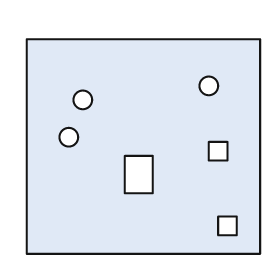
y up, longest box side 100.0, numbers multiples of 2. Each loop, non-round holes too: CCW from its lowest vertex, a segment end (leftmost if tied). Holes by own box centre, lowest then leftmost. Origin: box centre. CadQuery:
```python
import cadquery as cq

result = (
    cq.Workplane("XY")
    .moveTo(-50.0, -46.0)
    .lineTo(50.0, -46.0)
    .lineTo(50.0, 46.0)
    .lineTo(-50.0, 46.0)
    .close()
    .moveTo(32.0, -38.0)
    .lineTo(40.0, -38.0)
    .lineTo(40.0, -30.0)
    .lineTo(32.0, -30.0)
    .close()
    .moveTo(-8.0, -20.0)
    .lineTo(4.0, -20.0)
    .lineTo(4.0, -4.0)
    .lineTo(-8.0, -4.0)
    .close()
    .moveTo(28.0, -6.0)
    .lineTo(36.0, -6.0)
    .lineTo(36.0, 2.0)
    .lineTo(28.0, 2.0)
    .close()
    .moveTo(-32.0, 4.0)
    .circle(4.0)
    .moveTo(-26.0, 20.0)
    .circle(4.0)
    .moveTo(28.0, 26.0)
    .circle(4.0)
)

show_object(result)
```